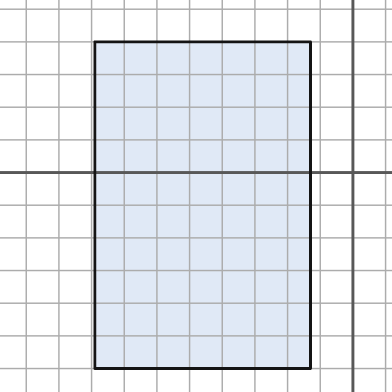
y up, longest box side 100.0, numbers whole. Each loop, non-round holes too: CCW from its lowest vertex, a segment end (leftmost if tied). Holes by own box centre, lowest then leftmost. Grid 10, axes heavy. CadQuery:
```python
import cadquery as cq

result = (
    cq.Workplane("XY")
    .moveTo(-79.0, -60.0)
    .lineTo(-13.0, -60.0)
    .lineTo(-13.0, 40.0)
    .lineTo(-79.0, 40.0)
    .close()
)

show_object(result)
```